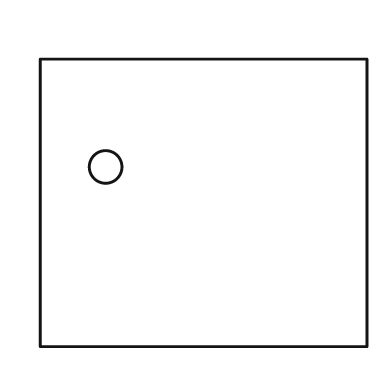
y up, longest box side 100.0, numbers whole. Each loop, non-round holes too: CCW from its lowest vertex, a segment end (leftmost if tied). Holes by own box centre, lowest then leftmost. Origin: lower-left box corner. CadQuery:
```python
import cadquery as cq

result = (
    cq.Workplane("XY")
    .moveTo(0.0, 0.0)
    .lineTo(100.0, 0.0)
    .lineTo(100.0, 88.0)
    .lineTo(0.0, 88.0)
    .close()
    .moveTo(20.0, 55.0)
    .circle(5.0)
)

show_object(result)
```